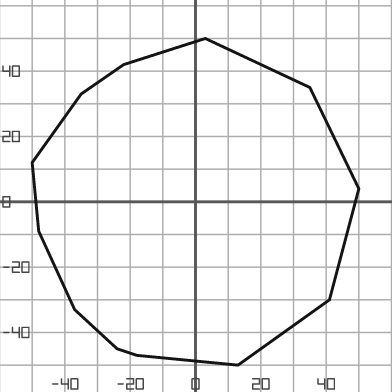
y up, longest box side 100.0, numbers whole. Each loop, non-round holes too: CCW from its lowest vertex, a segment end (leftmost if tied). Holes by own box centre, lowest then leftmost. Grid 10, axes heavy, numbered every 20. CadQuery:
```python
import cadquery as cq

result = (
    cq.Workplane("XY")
    .moveTo(13.0, -50.0)
    .lineTo(41.0, -30.0)
    .lineTo(50.0, 4.0)
    .lineTo(35.0, 35.0)
    .lineTo(3.0, 50.0)
    .lineTo(-22.0, 42.0)
    .lineTo(-35.0, 33.0)
    .lineTo(-50.0, 12.0)
    .lineTo(-48.0, -9.0)
    .lineTo(-37.0, -33.0)
    .lineTo(-24.0, -45.0)
    .lineTo(-18.0, -47.0)
    .close()
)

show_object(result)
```